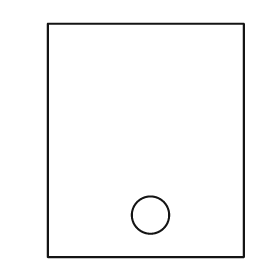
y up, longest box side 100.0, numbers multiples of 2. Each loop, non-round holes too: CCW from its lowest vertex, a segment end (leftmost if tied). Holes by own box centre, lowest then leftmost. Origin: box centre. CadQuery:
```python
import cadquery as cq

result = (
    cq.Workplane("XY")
    .moveTo(-42.0, -50.0)
    .lineTo(42.0, -50.0)
    .lineTo(42.0, 50.0)
    .lineTo(-42.0, 50.0)
    .close()
    .moveTo(2.0, -32.0)
    .circle(8.0)
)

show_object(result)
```